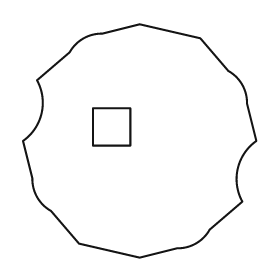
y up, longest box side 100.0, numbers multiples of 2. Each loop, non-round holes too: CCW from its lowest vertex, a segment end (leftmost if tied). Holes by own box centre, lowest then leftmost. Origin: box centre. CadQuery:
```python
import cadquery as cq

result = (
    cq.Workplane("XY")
    .moveTo(0.0, -50.0)
    .lineTo(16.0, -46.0)
    .threePointArc((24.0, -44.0), (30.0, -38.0))
    .lineTo(44.0, -26.0)
    .threePointArc((42.0, -12.0), (50.0, 0.0))
    .lineTo(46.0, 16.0)
    .threePointArc((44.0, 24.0), (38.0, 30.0))
    .lineTo(26.0, 44.0)
    .lineTo(0.0, 50.0)
    .lineTo(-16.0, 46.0)
    .threePointArc((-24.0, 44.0), (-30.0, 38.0))
    .lineTo(-44.0, 26.0)
    .threePointArc((-42.0, 12.0), (-50.0, 0.0))
    .lineTo(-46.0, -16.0)
    .threePointArc((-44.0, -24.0), (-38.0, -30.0))
    .lineTo(-26.0, -44.0)
    .close()
    .moveTo(-20.0, -2.0)
    .lineTo(-4.0, -2.0)
    .lineTo(-4.0, 14.0)
    .lineTo(-20.0, 14.0)
    .close()
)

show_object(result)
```